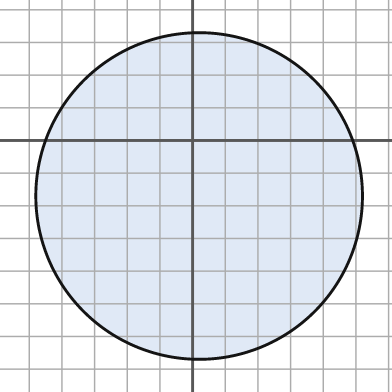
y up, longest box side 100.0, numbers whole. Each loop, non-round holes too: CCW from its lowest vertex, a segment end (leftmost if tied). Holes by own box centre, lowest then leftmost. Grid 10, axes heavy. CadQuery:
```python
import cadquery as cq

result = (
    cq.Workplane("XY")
    .moveTo(2.0, -17.0)
    .circle(50.0)
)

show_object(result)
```